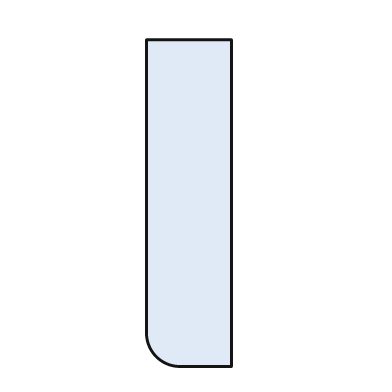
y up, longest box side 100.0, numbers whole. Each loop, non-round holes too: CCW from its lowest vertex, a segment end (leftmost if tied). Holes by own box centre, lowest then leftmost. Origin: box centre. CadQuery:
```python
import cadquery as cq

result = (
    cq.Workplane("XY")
    .moveTo(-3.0, -50.0)
    .lineTo(13.0, -50.0)
    .lineTo(13.0, 50.0)
    .lineTo(-13.0, 50.0)
    .lineTo(-13.0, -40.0)
    .threePointArc((-10.0, -47.0), (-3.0, -50.0))
    .close()
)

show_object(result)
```